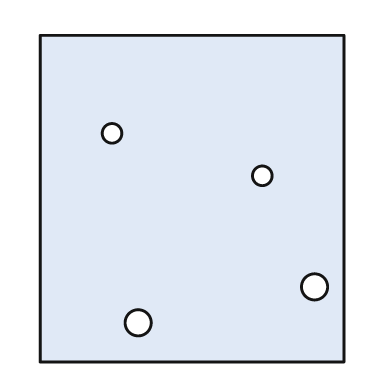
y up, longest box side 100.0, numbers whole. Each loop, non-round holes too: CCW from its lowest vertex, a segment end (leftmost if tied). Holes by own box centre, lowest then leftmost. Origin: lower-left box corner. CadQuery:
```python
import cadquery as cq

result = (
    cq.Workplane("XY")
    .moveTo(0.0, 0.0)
    .lineTo(93.0, 0.0)
    .lineTo(93.0, 100.0)
    .lineTo(0.0, 100.0)
    .close()
    .moveTo(30.0, 12.0)
    .circle(4.0)
    .moveTo(84.0, 23.0)
    .circle(4.0)
    .moveTo(68.0, 57.0)
    .circle(3.0)
    .moveTo(22.0, 70.0)
    .circle(3.0)
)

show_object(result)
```